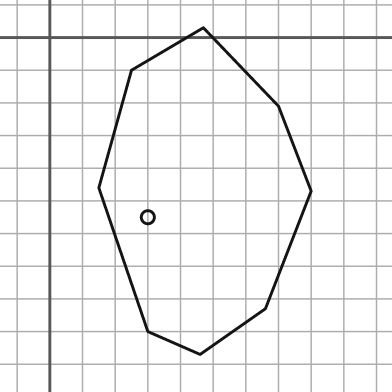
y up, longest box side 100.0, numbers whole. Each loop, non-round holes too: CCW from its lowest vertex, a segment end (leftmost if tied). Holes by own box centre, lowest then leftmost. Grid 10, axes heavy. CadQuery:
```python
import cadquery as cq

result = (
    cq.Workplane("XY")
    .moveTo(46.0, -97.0)
    .lineTo(66.0, -83.0)
    .lineTo(80.0, -47.0)
    .lineTo(70.0, -21.0)
    .lineTo(47.0, 3.0)
    .lineTo(25.0, -10.0)
    .lineTo(15.0, -46.0)
    .lineTo(30.0, -90.0)
    .close()
    .moveTo(30.0, -55.0)
    .circle(2.0)
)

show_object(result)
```